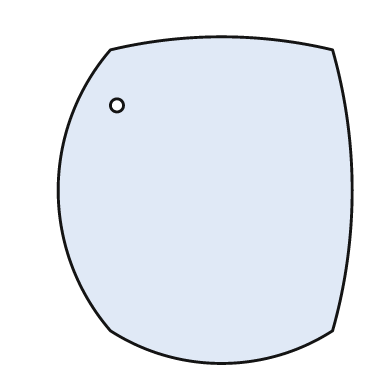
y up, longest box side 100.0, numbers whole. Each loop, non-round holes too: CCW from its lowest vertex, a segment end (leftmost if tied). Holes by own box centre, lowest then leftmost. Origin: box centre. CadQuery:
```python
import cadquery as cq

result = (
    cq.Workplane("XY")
    .moveTo(-29.0, -40.0)
    .threePointArc((5.0, -50.0), (39.0, -40.0))
    .threePointArc((45.0, 3.0), (39.0, 46.0))
    .threePointArc((5.0, 50.0), (-29.0, 46.0))
    .threePointArc((-45.0, 3.0), (-29.0, -40.0))
    .close()
    .moveTo(-27.0, 29.0)
    .circle(2.0)
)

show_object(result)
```